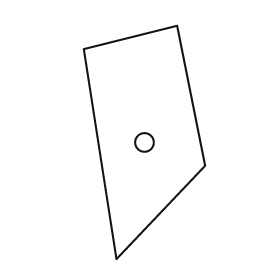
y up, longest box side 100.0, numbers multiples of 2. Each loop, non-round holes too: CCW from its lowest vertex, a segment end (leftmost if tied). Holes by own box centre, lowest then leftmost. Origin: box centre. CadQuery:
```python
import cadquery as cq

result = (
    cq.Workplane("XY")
    .moveTo(-12.0, -50.0)
    .lineTo(26.0, -10.0)
    .lineTo(14.0, 50.0)
    .lineTo(-26.0, 40.0)
    .close()
    .moveTo(0.0, 0.0)
    .circle(4.0)
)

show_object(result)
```